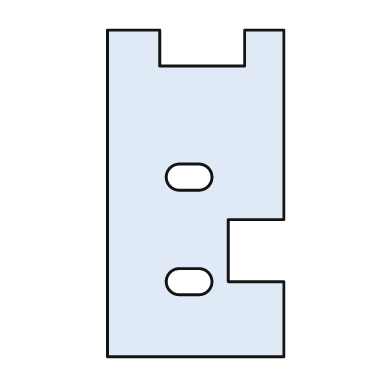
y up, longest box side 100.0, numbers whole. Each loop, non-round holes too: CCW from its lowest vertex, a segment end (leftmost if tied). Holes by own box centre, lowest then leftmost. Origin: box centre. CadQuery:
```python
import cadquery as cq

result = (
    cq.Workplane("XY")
    .moveTo(-27.0, -50.0)
    .lineTo(27.0, -50.0)
    .lineTo(27.0, -27.0)
    .lineTo(10.0, -27.0)
    .lineTo(10.0, -8.0)
    .lineTo(27.0, -8.0)
    .lineTo(27.0, 50.0)
    .lineTo(15.0, 50.0)
    .lineTo(15.0, 39.0)
    .lineTo(-11.0, 39.0)
    .lineTo(-11.0, 50.0)
    .lineTo(-27.0, 50.0)
    .close()
    .moveTo(-5.0, -31.0)
    .lineTo(1.0, -31.0)
    .threePointArc((5.0, -27.0), (1.0, -23.0))
    .lineTo(-5.0, -23.0)
    .threePointArc((-9.0, -27.0), (-5.0, -31.0))
    .close()
    .moveTo(-5.0, 1.0)
    .lineTo(1.0, 1.0)
    .threePointArc((5.0, 5.0), (1.0, 9.0))
    .lineTo(-5.0, 9.0)
    .threePointArc((-9.0, 5.0), (-5.0, 1.0))
    .close()
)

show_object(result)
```